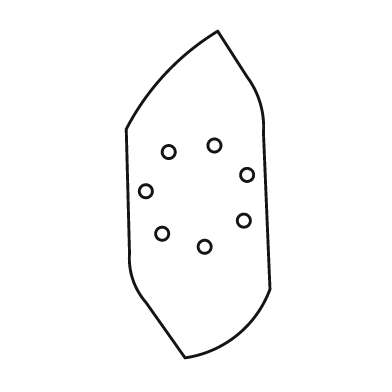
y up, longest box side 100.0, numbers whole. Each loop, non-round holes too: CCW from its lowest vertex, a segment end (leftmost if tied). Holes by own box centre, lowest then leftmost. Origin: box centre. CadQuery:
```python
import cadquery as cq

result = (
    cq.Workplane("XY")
    .moveTo(-4.0, -50.0)
    .threePointArc((12.0, -43.0), (22.0, -29.0))
    .lineTo(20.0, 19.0)
    .threePointArc((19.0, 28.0), (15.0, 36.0))
    .lineTo(6.0, 50.0)
    .threePointArc((-10.0, 37.0), (-22.0, 20.0))
    .lineTo(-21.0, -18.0)
    .threePointArc((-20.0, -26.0), (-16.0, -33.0))
    .close()
    .moveTo(2.0, -16.0)
    .circle(2.0)
    .moveTo(-11.0, -12.0)
    .circle(2.0)
    .moveTo(14.0, -8.0)
    .circle(2.0)
    .moveTo(-16.0, 1.0)
    .circle(2.0)
    .moveTo(15.0, 6.0)
    .circle(2.0)
    .moveTo(-9.0, 13.0)
    .circle(2.0)
    .moveTo(5.0, 15.0)
    .circle(2.0)
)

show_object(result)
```